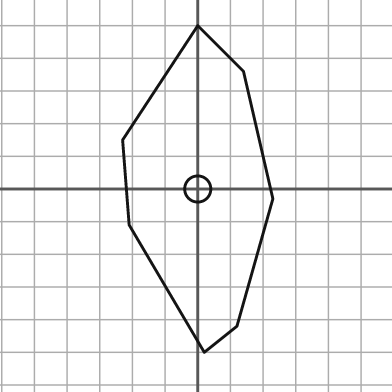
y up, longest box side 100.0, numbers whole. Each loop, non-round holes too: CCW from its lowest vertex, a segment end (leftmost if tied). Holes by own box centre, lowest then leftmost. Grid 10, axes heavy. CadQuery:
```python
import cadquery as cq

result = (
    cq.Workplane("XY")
    .moveTo(2.0, -50.0)
    .lineTo(12.0, -42.0)
    .lineTo(23.0, -3.0)
    .lineTo(14.0, 36.0)
    .lineTo(0.0, 50.0)
    .lineTo(-23.0, 15.0)
    .lineTo(-21.0, -11.0)
    .close()
    .moveTo(0.0, 0.0)
    .circle(4.0)
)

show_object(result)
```